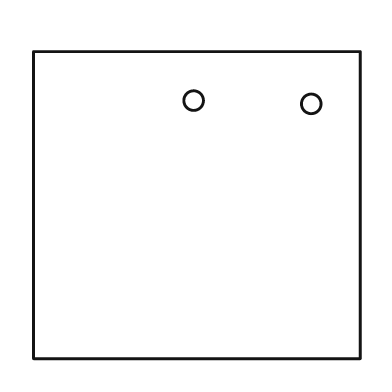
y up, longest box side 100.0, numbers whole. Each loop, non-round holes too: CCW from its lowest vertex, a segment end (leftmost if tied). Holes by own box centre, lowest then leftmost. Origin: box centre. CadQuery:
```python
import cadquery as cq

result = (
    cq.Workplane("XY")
    .moveTo(-50.0, -47.0)
    .lineTo(50.0, -47.0)
    .lineTo(50.0, 47.0)
    .lineTo(-50.0, 47.0)
    .close()
    .moveTo(35.0, 31.0)
    .circle(3.0)
    .moveTo(-1.0, 32.0)
    .circle(3.0)
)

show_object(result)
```